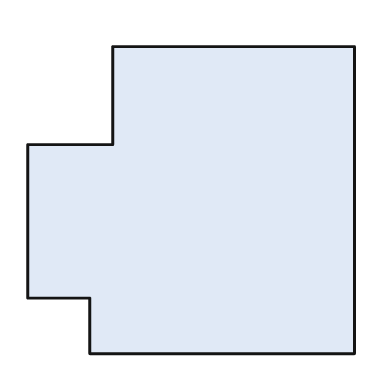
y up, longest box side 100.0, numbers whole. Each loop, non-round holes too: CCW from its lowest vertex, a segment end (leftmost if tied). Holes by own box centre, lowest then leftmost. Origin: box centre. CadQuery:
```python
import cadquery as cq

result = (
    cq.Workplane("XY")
    .moveTo(-31.0, -47.0)
    .lineTo(50.0, -47.0)
    .lineTo(50.0, 47.0)
    .lineTo(-24.0, 47.0)
    .lineTo(-24.0, 17.0)
    .lineTo(-50.0, 17.0)
    .lineTo(-50.0, -30.0)
    .lineTo(-31.0, -30.0)
    .close()
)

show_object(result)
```